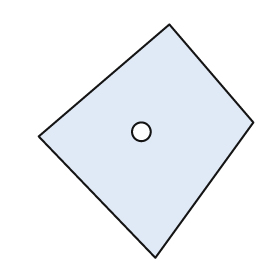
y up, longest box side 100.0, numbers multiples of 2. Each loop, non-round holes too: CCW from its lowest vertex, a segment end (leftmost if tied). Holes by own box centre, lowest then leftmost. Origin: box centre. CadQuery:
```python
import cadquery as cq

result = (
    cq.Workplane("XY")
    .moveTo(4.0, -50.0)
    .lineTo(46.0, 8.0)
    .lineTo(10.0, 50.0)
    .lineTo(-46.0, 2.0)
    .close()
    .moveTo(-2.0, 4.0)
    .circle(4.0)
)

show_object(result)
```